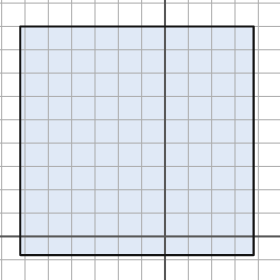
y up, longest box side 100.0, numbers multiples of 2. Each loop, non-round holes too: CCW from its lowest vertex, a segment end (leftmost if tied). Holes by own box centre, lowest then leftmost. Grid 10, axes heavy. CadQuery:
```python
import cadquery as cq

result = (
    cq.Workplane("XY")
    .moveTo(-62.0, -8.0)
    .lineTo(38.0, -8.0)
    .lineTo(38.0, 90.0)
    .lineTo(-62.0, 90.0)
    .close()
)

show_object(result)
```